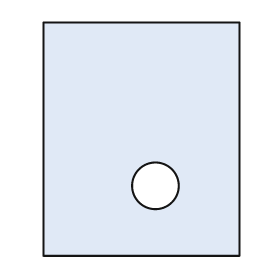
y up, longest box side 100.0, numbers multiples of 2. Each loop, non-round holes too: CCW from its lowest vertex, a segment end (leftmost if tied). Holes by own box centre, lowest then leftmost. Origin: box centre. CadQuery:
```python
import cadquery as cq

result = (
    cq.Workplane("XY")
    .moveTo(-42.0, -50.0)
    .lineTo(42.0, -50.0)
    .lineTo(42.0, 50.0)
    .lineTo(-42.0, 50.0)
    .close()
    .moveTo(6.0, -20.0)
    .circle(10.0)
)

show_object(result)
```